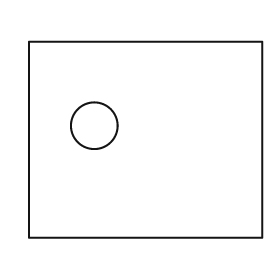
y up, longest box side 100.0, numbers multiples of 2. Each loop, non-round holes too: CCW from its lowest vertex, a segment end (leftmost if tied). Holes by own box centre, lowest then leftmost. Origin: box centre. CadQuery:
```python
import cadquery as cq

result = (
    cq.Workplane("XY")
    .moveTo(-50.0, -42.0)
    .lineTo(50.0, -42.0)
    .lineTo(50.0, 42.0)
    .lineTo(-50.0, 42.0)
    .close()
    .moveTo(-22.0, 6.0)
    .circle(10.0)
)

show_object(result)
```